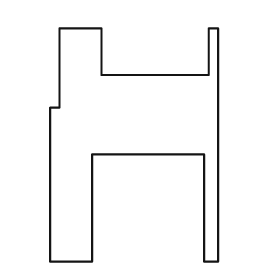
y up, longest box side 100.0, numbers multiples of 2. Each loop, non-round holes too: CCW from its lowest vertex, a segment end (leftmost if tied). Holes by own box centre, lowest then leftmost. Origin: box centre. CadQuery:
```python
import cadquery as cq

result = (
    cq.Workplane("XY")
    .moveTo(-36.0, -50.0)
    .lineTo(-18.0, -50.0)
    .lineTo(-18.0, -4.0)
    .lineTo(30.0, -4.0)
    .lineTo(30.0, -50.0)
    .lineTo(36.0, -50.0)
    .lineTo(36.0, 50.0)
    .lineTo(32.0, 50.0)
    .lineTo(32.0, 30.0)
    .lineTo(-14.0, 30.0)
    .lineTo(-14.0, 50.0)
    .lineTo(-32.0, 50.0)
    .lineTo(-32.0, 16.0)
    .lineTo(-36.0, 16.0)
    .close()
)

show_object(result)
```